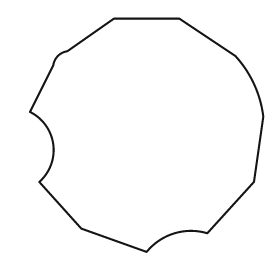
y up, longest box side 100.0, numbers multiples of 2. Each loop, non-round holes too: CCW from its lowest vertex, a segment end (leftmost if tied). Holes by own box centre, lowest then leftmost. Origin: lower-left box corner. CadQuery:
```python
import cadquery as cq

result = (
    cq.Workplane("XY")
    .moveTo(50.0, 0.0)
    .threePointArc((62.0, 8.0), (76.0, 8.0))
    .lineTo(96.0, 30.0)
    .lineTo(100.0, 58.0)
    .threePointArc((96.0, 72.0), (88.0, 84.0))
    .lineTo(64.0, 100.0)
    .lineTo(36.0, 100.0)
    .lineTo(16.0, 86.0)
    .threePointArc((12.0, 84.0), (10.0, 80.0))
    .lineTo(0.0, 60.0)
    .threePointArc((10.0, 46.0), (4.0, 30.0))
    .lineTo(22.0, 10.0)
    .close()
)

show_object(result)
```